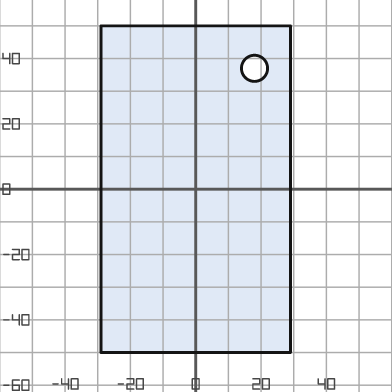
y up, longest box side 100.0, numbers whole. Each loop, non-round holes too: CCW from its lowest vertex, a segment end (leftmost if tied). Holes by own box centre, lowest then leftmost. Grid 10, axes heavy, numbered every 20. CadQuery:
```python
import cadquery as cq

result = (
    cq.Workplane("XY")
    .moveTo(-29.0, -50.0)
    .lineTo(29.0, -50.0)
    .lineTo(29.0, 50.0)
    .lineTo(-29.0, 50.0)
    .close()
    .moveTo(18.0, 37.0)
    .circle(4.0)
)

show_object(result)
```